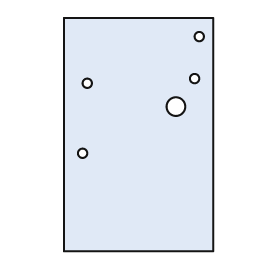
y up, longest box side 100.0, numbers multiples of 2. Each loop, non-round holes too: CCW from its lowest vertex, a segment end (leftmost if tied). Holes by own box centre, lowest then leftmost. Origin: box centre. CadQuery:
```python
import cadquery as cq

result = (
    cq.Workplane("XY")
    .moveTo(-32.0, -50.0)
    .lineTo(32.0, -50.0)
    .lineTo(32.0, 50.0)
    .lineTo(-32.0, 50.0)
    .close()
    .moveTo(-24.0, -8.0)
    .circle(2.0)
    .moveTo(16.0, 12.0)
    .circle(4.0)
    .moveTo(-22.0, 22.0)
    .circle(2.0)
    .moveTo(24.0, 24.0)
    .circle(2.0)
    .moveTo(26.0, 42.0)
    .circle(2.0)
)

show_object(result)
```